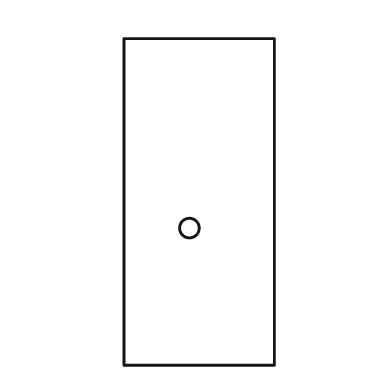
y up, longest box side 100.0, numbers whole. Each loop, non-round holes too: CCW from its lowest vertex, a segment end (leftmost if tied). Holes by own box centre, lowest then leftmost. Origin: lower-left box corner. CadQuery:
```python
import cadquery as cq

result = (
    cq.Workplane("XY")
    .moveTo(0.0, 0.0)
    .lineTo(46.0, 0.0)
    .lineTo(46.0, 100.0)
    .lineTo(0.0, 100.0)
    .close()
    .moveTo(20.0, 42.0)
    .circle(3.0)
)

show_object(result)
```